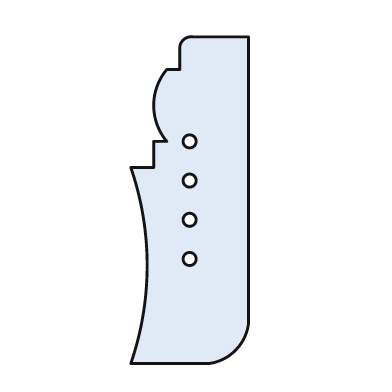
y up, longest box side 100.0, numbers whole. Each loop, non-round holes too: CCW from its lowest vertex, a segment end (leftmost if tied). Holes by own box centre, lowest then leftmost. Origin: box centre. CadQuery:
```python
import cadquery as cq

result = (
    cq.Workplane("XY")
    .moveTo(-18.0, -50.0)
    .lineTo(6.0, -50.0)
    .threePointArc((14.0, -46.0), (18.0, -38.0))
    .lineTo(18.0, 50.0)
    .lineTo(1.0, 50.0)
    .threePointArc((-2.0, 49.0), (-3.0, 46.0))
    .lineTo(-3.0, 40.0)
    .lineTo(-7.0, 40.0)
    .threePointArc((-11.0, 29.0), (-7.0, 18.0))
    .lineTo(-11.0, 18.0)
    .lineTo(-11.0, 10.0)
    .lineTo(-18.0, 10.0)
    .threePointArc((-13.0, -20.0), (-18.0, -50.0))
    .close()
    .moveTo(0.0, -18.0)
    .circle(2.0)
    .moveTo(0.0, -6.0)
    .circle(2.0)
    .moveTo(0.0, 6.0)
    .circle(2.0)
    .moveTo(0.0, 18.0)
    .circle(2.0)
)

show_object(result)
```